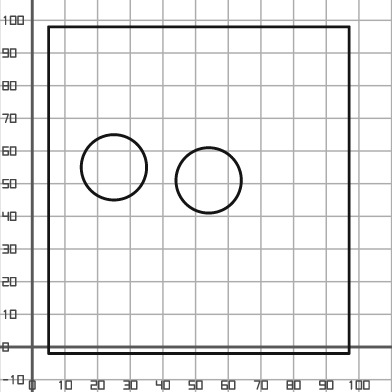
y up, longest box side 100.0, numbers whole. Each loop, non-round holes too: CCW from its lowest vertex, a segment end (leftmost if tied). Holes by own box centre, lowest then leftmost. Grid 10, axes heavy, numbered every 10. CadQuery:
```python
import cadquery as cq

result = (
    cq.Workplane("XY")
    .moveTo(5.0, -2.0)
    .lineTo(97.0, -2.0)
    .lineTo(97.0, 98.0)
    .lineTo(5.0, 98.0)
    .close()
    .moveTo(54.0, 51.0)
    .circle(10.0)
    .moveTo(25.0, 55.0)
    .circle(10.0)
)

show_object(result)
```